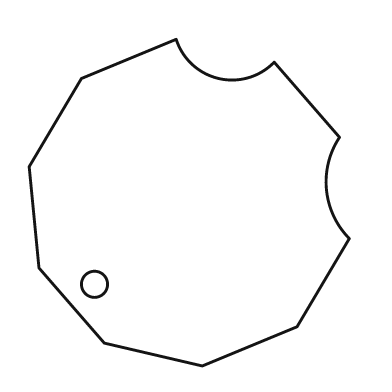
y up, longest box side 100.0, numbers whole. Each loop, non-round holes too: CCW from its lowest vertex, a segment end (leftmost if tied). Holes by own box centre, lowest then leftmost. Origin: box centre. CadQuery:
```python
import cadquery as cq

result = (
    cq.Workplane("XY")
    .moveTo(4.0, -50.0)
    .lineTo(33.0, -38.0)
    .lineTo(49.0, -11.0)
    .threePointArc((42.0, 4.0), (46.0, 20.0))
    .lineTo(26.0, 43.0)
    .threePointArc((9.0, 38.0), (-4.0, 50.0))
    .lineTo(-33.0, 38.0)
    .lineTo(-49.0, 11.0)
    .lineTo(-46.0, -20.0)
    .lineTo(-26.0, -43.0)
    .close()
    .moveTo(-29.0, -25.0)
    .circle(4.0)
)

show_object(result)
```